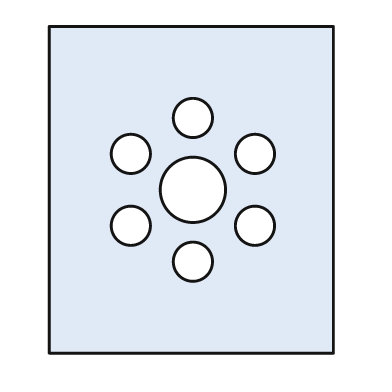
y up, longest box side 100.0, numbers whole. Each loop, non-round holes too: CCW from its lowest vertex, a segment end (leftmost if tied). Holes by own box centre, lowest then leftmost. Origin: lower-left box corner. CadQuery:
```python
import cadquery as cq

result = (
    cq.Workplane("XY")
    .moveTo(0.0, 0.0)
    .lineTo(87.0, 0.0)
    .lineTo(87.0, 100.0)
    .lineTo(0.0, 100.0)
    .close()
    .moveTo(44.0, 28.0)
    .circle(6.0)
    .moveTo(25.0, 39.0)
    .circle(6.0)
    .moveTo(63.0, 39.0)
    .circle(6.0)
    .moveTo(44.0, 50.0)
    .circle(10.0)
    .moveTo(25.0, 61.0)
    .circle(6.0)
    .moveTo(63.0, 61.0)
    .circle(6.0)
    .moveTo(44.0, 72.0)
    .circle(6.0)
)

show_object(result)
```